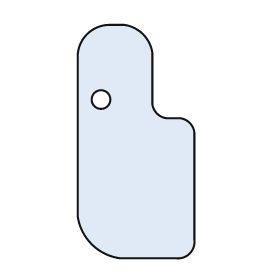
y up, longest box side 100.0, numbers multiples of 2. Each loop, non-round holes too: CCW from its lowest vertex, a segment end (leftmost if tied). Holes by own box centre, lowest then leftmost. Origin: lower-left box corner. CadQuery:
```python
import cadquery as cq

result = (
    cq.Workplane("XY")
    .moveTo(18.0, 0.0)
    .lineTo(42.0, 0.0)
    .threePointArc((48.0, 2.0), (50.0, 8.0))
    .lineTo(50.0, 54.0)
    .threePointArc((48.0, 58.0), (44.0, 60.0))
    .lineTo(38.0, 60.0)
    .threePointArc((34.0, 62.0), (32.0, 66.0))
    .lineTo(32.0, 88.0)
    .threePointArc((28.0, 96.0), (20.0, 100.0))
    .lineTo(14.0, 100.0)
    .threePointArc((4.0, 96.0), (0.0, 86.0))
    .lineTo(0.0, 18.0)
    .threePointArc((6.0, 6.0), (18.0, 0.0))
    .close()
    .moveTo(10.0, 68.0)
    .circle(4.0)
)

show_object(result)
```